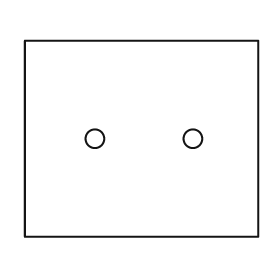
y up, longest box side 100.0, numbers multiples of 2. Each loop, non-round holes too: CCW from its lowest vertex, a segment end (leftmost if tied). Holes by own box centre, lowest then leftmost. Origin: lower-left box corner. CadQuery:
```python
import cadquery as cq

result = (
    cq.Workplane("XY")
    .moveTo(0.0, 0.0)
    .lineTo(100.0, 0.0)
    .lineTo(100.0, 84.0)
    .lineTo(0.0, 84.0)
    .close()
    .moveTo(30.0, 42.0)
    .circle(4.0)
    .moveTo(72.0, 42.0)
    .circle(4.0)
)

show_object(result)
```